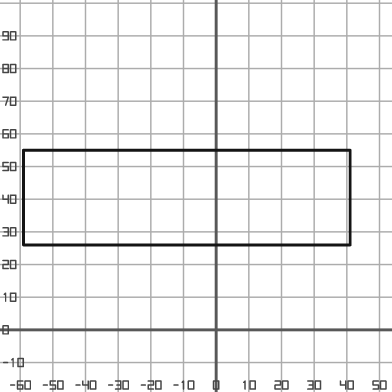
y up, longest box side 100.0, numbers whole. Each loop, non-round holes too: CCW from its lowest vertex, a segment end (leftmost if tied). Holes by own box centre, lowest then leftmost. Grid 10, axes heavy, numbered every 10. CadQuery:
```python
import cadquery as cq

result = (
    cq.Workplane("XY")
    .moveTo(-59.0, 26.0)
    .lineTo(41.0, 26.0)
    .lineTo(41.0, 55.0)
    .lineTo(-59.0, 55.0)
    .close()
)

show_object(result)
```